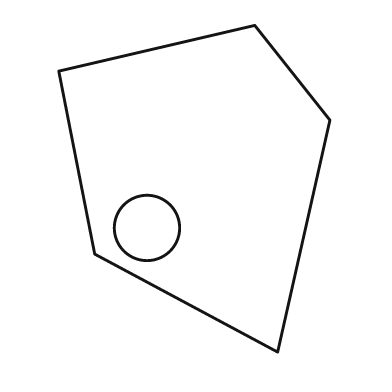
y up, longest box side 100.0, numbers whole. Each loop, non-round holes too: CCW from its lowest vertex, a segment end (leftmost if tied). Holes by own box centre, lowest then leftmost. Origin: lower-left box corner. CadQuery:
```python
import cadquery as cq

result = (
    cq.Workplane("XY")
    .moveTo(67.0, 0.0)
    .lineTo(83.0, 71.0)
    .lineTo(60.0, 100.0)
    .lineTo(0.0, 86.0)
    .lineTo(11.0, 30.0)
    .close()
    .moveTo(27.0, 38.0)
    .circle(10.0)
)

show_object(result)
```